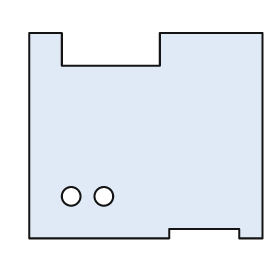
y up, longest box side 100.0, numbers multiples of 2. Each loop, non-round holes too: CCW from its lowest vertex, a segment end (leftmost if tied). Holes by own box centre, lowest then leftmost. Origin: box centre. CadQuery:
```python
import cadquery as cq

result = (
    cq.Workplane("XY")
    .moveTo(-50.0, -44.0)
    .lineTo(10.0, -44.0)
    .lineTo(10.0, -40.0)
    .lineTo(40.0, -40.0)
    .lineTo(40.0, -44.0)
    .lineTo(50.0, -44.0)
    .lineTo(50.0, 44.0)
    .lineTo(6.0, 44.0)
    .lineTo(6.0, 30.0)
    .lineTo(-36.0, 30.0)
    .lineTo(-36.0, 44.0)
    .lineTo(-50.0, 44.0)
    .close()
    .moveTo(-32.0, -26.0)
    .circle(4.0)
    .moveTo(-18.0, -26.0)
    .circle(4.0)
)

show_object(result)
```